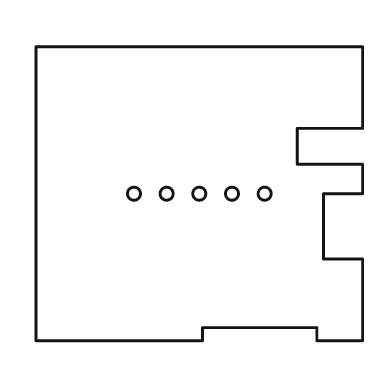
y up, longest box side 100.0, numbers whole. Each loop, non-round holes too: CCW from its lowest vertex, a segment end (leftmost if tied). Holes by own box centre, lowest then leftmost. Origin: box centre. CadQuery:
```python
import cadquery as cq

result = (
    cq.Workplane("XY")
    .moveTo(-50.0, -45.0)
    .lineTo(1.0, -45.0)
    .lineTo(1.0, -41.0)
    .lineTo(36.0, -41.0)
    .lineTo(36.0, -45.0)
    .lineTo(50.0, -45.0)
    .lineTo(50.0, -20.0)
    .lineTo(38.0, -20.0)
    .lineTo(38.0, 0.0)
    .lineTo(50.0, 0.0)
    .lineTo(50.0, 9.0)
    .lineTo(30.0, 9.0)
    .lineTo(30.0, 20.0)
    .lineTo(50.0, 20.0)
    .lineTo(50.0, 45.0)
    .lineTo(-50.0, 45.0)
    .close()
    .moveTo(-20.0, 0.0)
    .circle(2.0)
    .moveTo(-10.0, 0.0)
    .circle(2.0)
    .moveTo(0.0, 0.0)
    .circle(2.0)
    .moveTo(10.0, 0.0)
    .circle(2.0)
    .moveTo(20.0, 0.0)
    .circle(2.0)
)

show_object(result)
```